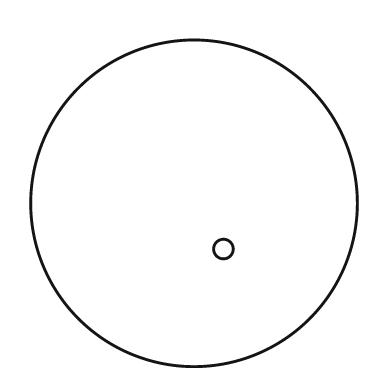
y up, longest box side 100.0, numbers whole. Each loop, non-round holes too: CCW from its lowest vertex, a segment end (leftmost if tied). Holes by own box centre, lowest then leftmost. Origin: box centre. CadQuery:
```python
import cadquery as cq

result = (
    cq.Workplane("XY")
    .moveTo(0.0, 0.0)
    .circle(50.0)
    .moveTo(9.0, -14.0)
    .circle(3.0)
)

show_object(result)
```